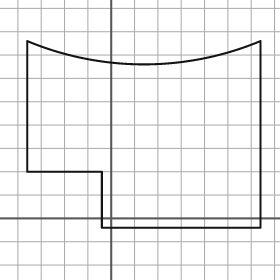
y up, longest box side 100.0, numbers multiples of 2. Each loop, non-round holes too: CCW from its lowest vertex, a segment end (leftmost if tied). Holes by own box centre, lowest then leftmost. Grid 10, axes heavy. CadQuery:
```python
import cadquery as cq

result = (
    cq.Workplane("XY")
    .moveTo(-4.0, -4.0)
    .lineTo(64.0, -4.0)
    .lineTo(64.0, 76.0)
    .threePointArc((14.0, 66.0), (-36.0, 76.0))
    .lineTo(-36.0, 20.0)
    .lineTo(-4.0, 20.0)
    .close()
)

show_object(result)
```